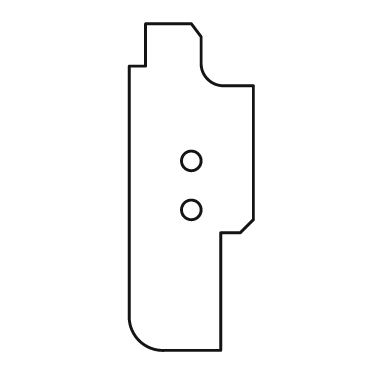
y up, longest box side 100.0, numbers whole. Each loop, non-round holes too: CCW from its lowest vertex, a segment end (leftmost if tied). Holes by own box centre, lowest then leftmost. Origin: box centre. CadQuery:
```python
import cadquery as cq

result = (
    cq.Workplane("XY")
    .moveTo(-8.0, -50.0)
    .lineTo(9.0, -50.0)
    .lineTo(9.0, -14.0)
    .lineTo(15.0, -14.0)
    .lineTo(19.0, -10.0)
    .lineTo(19.0, 31.0)
    .lineTo(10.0, 31.0)
    .threePointArc((5.0, 33.0), (3.0, 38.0))
    .lineTo(3.0, 46.0)
    .lineTo(0.0, 50.0)
    .lineTo(-14.0, 50.0)
    .lineTo(-14.0, 37.0)
    .lineTo(-19.0, 37.0)
    .lineTo(-19.0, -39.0)
    .threePointArc((-16.0, -47.0), (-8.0, -50.0))
    .close()
    .moveTo(0.0, -7.0)
    .circle(3.0)
    .moveTo(0.0, 8.0)
    .circle(3.0)
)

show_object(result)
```